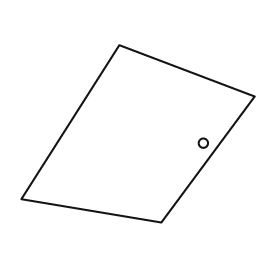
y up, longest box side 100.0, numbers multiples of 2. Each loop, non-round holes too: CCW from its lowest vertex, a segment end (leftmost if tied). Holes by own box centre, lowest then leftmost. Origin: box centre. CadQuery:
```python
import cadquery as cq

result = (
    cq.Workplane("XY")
    .moveTo(10.0, -38.0)
    .lineTo(50.0, 16.0)
    .lineTo(-8.0, 38.0)
    .lineTo(-50.0, -28.0)
    .close()
    .moveTo(28.0, -4.0)
    .circle(2.0)
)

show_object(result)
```